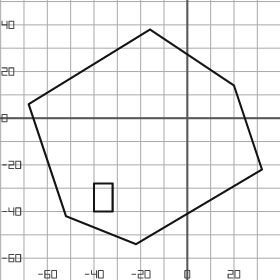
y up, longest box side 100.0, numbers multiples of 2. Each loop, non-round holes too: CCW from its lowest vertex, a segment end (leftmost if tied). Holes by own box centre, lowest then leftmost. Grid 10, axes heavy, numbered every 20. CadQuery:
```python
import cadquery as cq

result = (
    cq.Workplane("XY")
    .moveTo(-22.0, -54.0)
    .lineTo(32.0, -22.0)
    .lineTo(20.0, 14.0)
    .lineTo(-16.0, 38.0)
    .lineTo(-68.0, 6.0)
    .lineTo(-52.0, -42.0)
    .close()
    .moveTo(-40.0, -40.0)
    .lineTo(-32.0, -40.0)
    .lineTo(-32.0, -28.0)
    .lineTo(-40.0, -28.0)
    .close()
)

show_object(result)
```